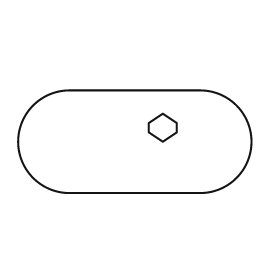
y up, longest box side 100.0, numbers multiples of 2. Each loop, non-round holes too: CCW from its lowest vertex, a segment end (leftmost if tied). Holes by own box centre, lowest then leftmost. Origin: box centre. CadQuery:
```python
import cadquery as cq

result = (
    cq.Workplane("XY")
    .moveTo(-28.0, -22.0)
    .lineTo(28.0, -22.0)
    .threePointArc((50.0, 0.0), (28.0, 22.0))
    .lineTo(-28.0, 22.0)
    .threePointArc((-50.0, 0.0), (-28.0, -22.0))
    .close()
    .moveTo(12.0, 0.0)
    .lineTo(18.0, 4.0)
    .lineTo(18.0, 8.0)
    .lineTo(12.0, 12.0)
    .lineTo(6.0, 8.0)
    .lineTo(6.0, 4.0)
    .close()
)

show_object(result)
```